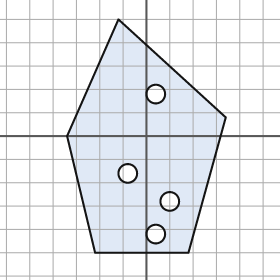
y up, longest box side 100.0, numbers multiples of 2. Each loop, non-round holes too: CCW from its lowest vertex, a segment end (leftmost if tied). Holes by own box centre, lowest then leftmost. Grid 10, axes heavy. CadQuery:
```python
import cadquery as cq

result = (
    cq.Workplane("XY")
    .moveTo(-22.0, -50.0)
    .lineTo(18.0, -50.0)
    .lineTo(34.0, 8.0)
    .lineTo(-12.0, 50.0)
    .lineTo(-34.0, 0.0)
    .close()
    .moveTo(4.0, -42.0)
    .circle(4.0)
    .moveTo(10.0, -28.0)
    .circle(4.0)
    .moveTo(-8.0, -16.0)
    .circle(4.0)
    .moveTo(4.0, 18.0)
    .circle(4.0)
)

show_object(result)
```